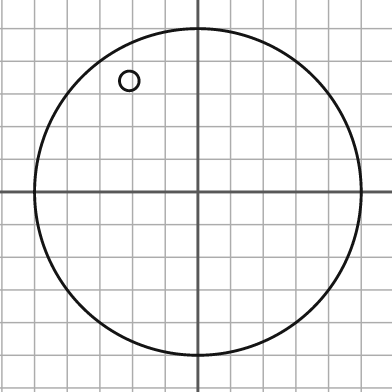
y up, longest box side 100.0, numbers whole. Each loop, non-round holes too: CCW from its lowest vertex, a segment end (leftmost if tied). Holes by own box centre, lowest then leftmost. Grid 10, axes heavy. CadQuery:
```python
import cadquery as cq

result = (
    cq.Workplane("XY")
    .moveTo(0.0, 0.0)
    .circle(50.0)
    .moveTo(-21.0, 34.0)
    .circle(3.0)
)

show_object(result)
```